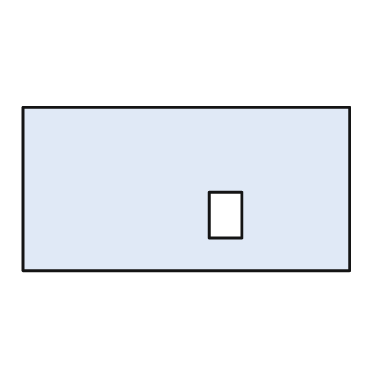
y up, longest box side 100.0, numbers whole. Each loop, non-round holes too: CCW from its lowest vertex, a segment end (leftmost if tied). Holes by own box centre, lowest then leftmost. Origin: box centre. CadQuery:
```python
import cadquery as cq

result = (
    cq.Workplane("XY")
    .moveTo(-50.0, -25.0)
    .lineTo(50.0, -25.0)
    .lineTo(50.0, 25.0)
    .lineTo(-50.0, 25.0)
    .close()
    .moveTo(7.0, -15.0)
    .lineTo(17.0, -15.0)
    .lineTo(17.0, -1.0)
    .lineTo(7.0, -1.0)
    .close()
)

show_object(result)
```